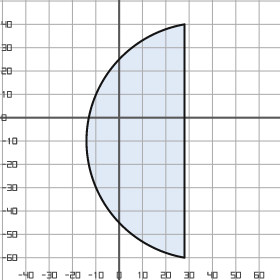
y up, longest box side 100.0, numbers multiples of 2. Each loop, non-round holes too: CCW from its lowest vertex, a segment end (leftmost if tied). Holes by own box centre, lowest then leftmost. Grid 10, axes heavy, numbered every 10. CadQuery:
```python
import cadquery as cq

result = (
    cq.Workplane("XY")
    .moveTo(28.0, -60.0)
    .lineTo(28.0, 40.0)
    .threePointArc((-14.0, -10.0), (28.0, -60.0))
    .close()
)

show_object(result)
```